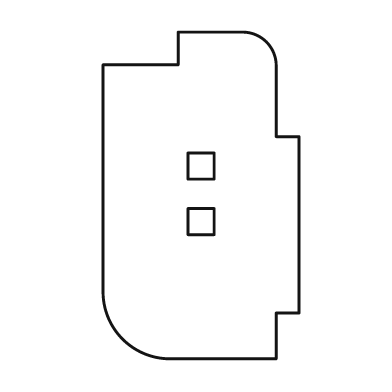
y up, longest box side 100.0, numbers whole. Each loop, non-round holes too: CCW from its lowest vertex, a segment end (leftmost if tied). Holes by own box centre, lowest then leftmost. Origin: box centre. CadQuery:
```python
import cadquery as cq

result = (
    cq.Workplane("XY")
    .moveTo(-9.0, -50.0)
    .lineTo(23.0, -50.0)
    .lineTo(23.0, -36.0)
    .lineTo(30.0, -36.0)
    .lineTo(30.0, 18.0)
    .lineTo(23.0, 18.0)
    .lineTo(23.0, 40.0)
    .threePointArc((20.0, 47.0), (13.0, 50.0))
    .lineTo(-7.0, 50.0)
    .lineTo(-7.0, 40.0)
    .lineTo(-30.0, 40.0)
    .lineTo(-30.0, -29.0)
    .threePointArc((-24.0, -44.0), (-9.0, -50.0))
    .close()
    .moveTo(-4.0, -12.0)
    .lineTo(4.0, -12.0)
    .lineTo(4.0, -4.0)
    .lineTo(-4.0, -4.0)
    .close()
    .moveTo(-4.0, 5.0)
    .lineTo(4.0, 5.0)
    .lineTo(4.0, 13.0)
    .lineTo(-4.0, 13.0)
    .close()
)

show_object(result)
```